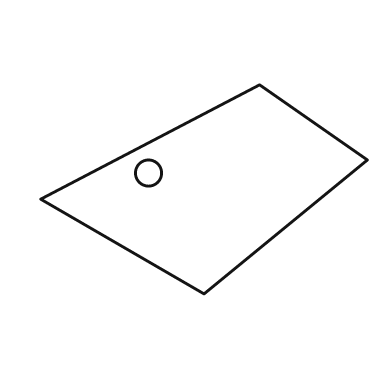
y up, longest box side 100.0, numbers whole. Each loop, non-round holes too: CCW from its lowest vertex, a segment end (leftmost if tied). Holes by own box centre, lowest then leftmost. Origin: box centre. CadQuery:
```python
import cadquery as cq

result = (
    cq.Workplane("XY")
    .moveTo(0.0, -32.0)
    .lineTo(50.0, 9.0)
    .lineTo(17.0, 32.0)
    .lineTo(-50.0, -3.0)
    .close()
    .moveTo(-17.0, 5.0)
    .circle(4.0)
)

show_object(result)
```